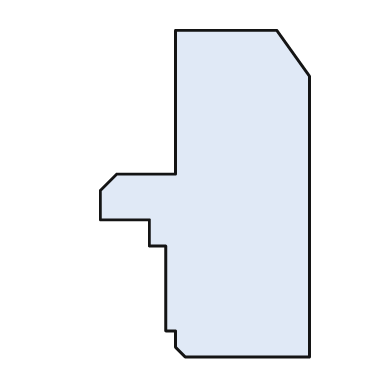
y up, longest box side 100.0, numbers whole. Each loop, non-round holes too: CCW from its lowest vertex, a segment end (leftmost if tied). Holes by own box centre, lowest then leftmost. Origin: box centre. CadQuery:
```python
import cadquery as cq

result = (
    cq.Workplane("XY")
    .moveTo(-6.0, -50.0)
    .lineTo(32.0, -50.0)
    .lineTo(32.0, 36.0)
    .lineTo(22.0, 50.0)
    .lineTo(-9.0, 50.0)
    .lineTo(-9.0, 6.0)
    .lineTo(-27.0, 6.0)
    .lineTo(-32.0, 1.0)
    .lineTo(-32.0, -8.0)
    .lineTo(-17.0, -8.0)
    .lineTo(-17.0, -16.0)
    .lineTo(-12.0, -16.0)
    .lineTo(-12.0, -42.0)
    .lineTo(-9.0, -42.0)
    .lineTo(-9.0, -47.0)
    .close()
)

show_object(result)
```